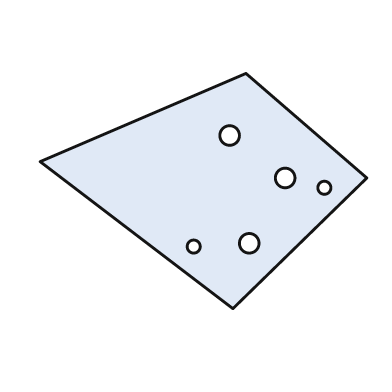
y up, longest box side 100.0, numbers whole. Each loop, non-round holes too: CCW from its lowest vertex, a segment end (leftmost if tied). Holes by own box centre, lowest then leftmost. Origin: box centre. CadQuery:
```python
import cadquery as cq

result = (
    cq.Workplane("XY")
    .moveTo(9.0, -36.0)
    .lineTo(50.0, 4.0)
    .lineTo(13.0, 36.0)
    .lineTo(-50.0, 9.0)
    .close()
    .moveTo(-3.0, -17.0)
    .circle(2.0)
    .moveTo(14.0, -16.0)
    .circle(3.0)
    .moveTo(37.0, 1.0)
    .circle(2.0)
    .moveTo(25.0, 4.0)
    .circle(3.0)
    .moveTo(8.0, 17.0)
    .circle(3.0)
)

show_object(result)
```